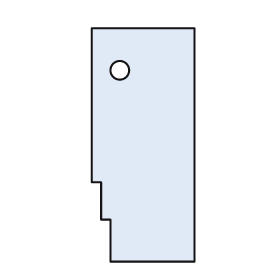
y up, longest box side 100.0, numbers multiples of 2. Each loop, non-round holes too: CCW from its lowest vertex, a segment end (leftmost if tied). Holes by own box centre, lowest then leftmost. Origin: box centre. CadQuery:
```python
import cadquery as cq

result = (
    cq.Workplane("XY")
    .moveTo(-14.0, -50.0)
    .lineTo(22.0, -50.0)
    .lineTo(22.0, 50.0)
    .lineTo(-22.0, 50.0)
    .lineTo(-22.0, -16.0)
    .lineTo(-18.0, -16.0)
    .lineTo(-18.0, -32.0)
    .lineTo(-14.0, -32.0)
    .close()
    .moveTo(-10.0, 32.0)
    .circle(4.0)
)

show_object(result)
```